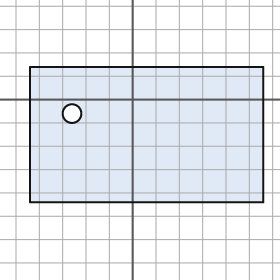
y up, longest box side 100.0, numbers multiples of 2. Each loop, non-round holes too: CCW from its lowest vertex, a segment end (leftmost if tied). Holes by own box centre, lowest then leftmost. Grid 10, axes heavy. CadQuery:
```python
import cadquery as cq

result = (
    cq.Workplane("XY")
    .moveTo(-44.0, -44.0)
    .lineTo(56.0, -44.0)
    .lineTo(56.0, 14.0)
    .lineTo(-44.0, 14.0)
    .close()
    .moveTo(-26.0, -6.0)
    .circle(4.0)
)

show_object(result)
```